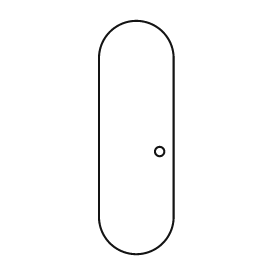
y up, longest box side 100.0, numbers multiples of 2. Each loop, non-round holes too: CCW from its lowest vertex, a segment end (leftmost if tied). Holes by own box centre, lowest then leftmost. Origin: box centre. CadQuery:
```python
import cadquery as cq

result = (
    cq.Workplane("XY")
    .moveTo(-16.0, -34.0)
    .threePointArc((0.0, -50.0), (16.0, -34.0))
    .lineTo(16.0, 34.0)
    .threePointArc((0.0, 50.0), (-16.0, 34.0))
    .close()
    .moveTo(10.0, -6.0)
    .circle(2.0)
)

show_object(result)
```